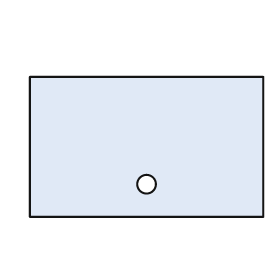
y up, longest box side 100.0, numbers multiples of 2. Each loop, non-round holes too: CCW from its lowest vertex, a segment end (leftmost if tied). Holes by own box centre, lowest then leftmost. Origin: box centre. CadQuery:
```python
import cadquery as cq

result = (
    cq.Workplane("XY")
    .moveTo(-50.0, -30.0)
    .lineTo(50.0, -30.0)
    .lineTo(50.0, 30.0)
    .lineTo(-50.0, 30.0)
    .close()
    .moveTo(0.0, -16.0)
    .circle(4.0)
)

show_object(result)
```